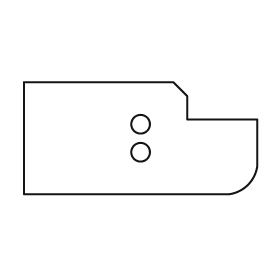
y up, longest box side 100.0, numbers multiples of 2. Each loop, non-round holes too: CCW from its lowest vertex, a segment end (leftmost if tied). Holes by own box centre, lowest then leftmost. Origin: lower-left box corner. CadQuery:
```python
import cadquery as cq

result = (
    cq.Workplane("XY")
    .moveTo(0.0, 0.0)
    .lineTo(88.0, 0.0)
    .threePointArc((96.0, 4.0), (100.0, 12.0))
    .lineTo(100.0, 32.0)
    .lineTo(70.0, 32.0)
    .lineTo(70.0, 42.0)
    .lineTo(64.0, 48.0)
    .lineTo(0.0, 48.0)
    .close()
    .moveTo(50.0, 18.0)
    .circle(4.0)
    .moveTo(50.0, 30.0)
    .circle(4.0)
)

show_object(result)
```